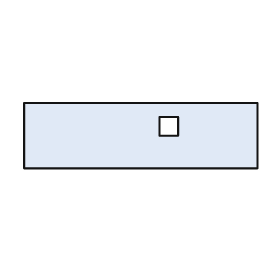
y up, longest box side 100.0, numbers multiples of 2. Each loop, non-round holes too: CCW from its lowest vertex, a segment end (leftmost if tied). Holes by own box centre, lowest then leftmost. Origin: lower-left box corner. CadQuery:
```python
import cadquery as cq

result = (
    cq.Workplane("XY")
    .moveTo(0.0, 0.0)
    .lineTo(100.0, 0.0)
    .lineTo(100.0, 28.0)
    .lineTo(0.0, 28.0)
    .close()
    .moveTo(58.0, 14.0)
    .lineTo(66.0, 14.0)
    .lineTo(66.0, 22.0)
    .lineTo(58.0, 22.0)
    .close()
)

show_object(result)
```